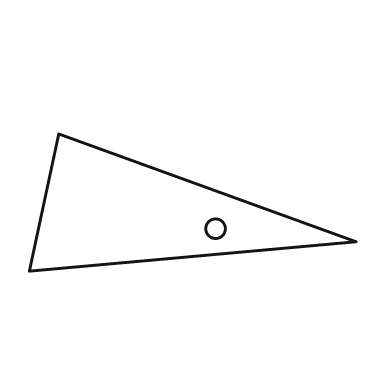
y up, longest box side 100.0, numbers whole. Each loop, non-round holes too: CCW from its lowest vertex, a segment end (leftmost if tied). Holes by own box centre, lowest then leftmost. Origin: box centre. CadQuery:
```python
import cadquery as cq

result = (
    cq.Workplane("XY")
    .moveTo(-50.0, -21.0)
    .lineTo(50.0, -12.0)
    .lineTo(-41.0, 21.0)
    .close()
    .moveTo(7.0, -8.0)
    .circle(3.0)
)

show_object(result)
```